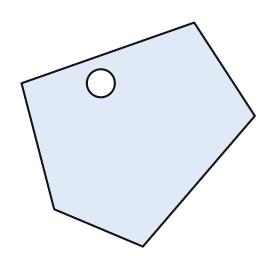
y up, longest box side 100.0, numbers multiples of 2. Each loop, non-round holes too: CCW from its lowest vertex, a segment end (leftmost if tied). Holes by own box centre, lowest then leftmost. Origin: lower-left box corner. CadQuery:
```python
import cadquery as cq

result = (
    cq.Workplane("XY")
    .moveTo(52.0, 0.0)
    .lineTo(100.0, 56.0)
    .lineTo(74.0, 96.0)
    .lineTo(0.0, 70.0)
    .lineTo(14.0, 16.0)
    .close()
    .moveTo(34.0, 70.0)
    .circle(6.0)
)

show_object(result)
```